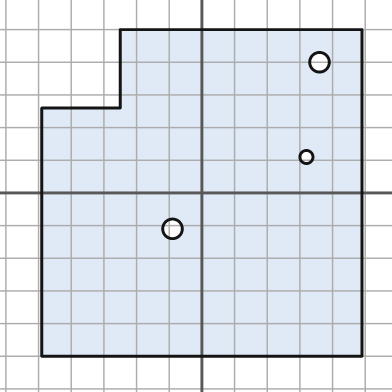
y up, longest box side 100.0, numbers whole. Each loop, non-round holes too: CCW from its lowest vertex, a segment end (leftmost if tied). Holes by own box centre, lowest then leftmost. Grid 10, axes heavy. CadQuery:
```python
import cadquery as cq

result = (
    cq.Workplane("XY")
    .moveTo(-49.0, -50.0)
    .lineTo(49.0, -50.0)
    .lineTo(49.0, 50.0)
    .lineTo(-25.0, 50.0)
    .lineTo(-25.0, 26.0)
    .lineTo(-49.0, 26.0)
    .close()
    .moveTo(-9.0, -11.0)
    .circle(3.0)
    .moveTo(32.0, 11.0)
    .circle(2.0)
    .moveTo(36.0, 40.0)
    .circle(3.0)
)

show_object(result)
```